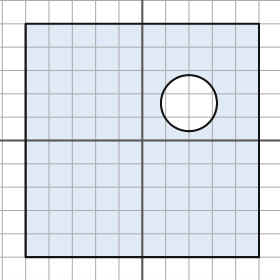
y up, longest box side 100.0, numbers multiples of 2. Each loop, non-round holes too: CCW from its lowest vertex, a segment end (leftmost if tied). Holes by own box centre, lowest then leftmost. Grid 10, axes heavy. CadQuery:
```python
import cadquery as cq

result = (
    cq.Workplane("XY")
    .moveTo(-50.0, -50.0)
    .lineTo(50.0, -50.0)
    .lineTo(50.0, 50.0)
    .lineTo(-50.0, 50.0)
    .close()
    .moveTo(20.0, 16.0)
    .circle(12.0)
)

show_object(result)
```